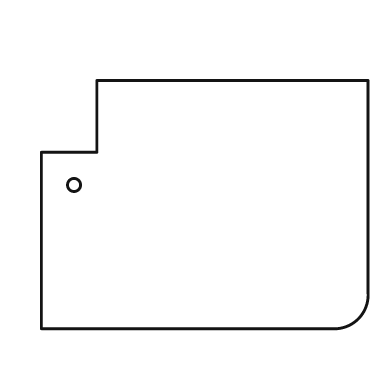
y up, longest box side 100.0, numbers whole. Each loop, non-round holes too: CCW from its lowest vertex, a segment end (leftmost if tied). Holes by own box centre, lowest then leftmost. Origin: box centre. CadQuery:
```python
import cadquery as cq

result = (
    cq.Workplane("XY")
    .moveTo(-50.0, -38.0)
    .lineTo(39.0, -38.0)
    .threePointArc((47.0, -35.0), (50.0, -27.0))
    .lineTo(50.0, 38.0)
    .lineTo(-33.0, 38.0)
    .lineTo(-33.0, 16.0)
    .lineTo(-50.0, 16.0)
    .close()
    .moveTo(-40.0, 6.0)
    .circle(2.0)
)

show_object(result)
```